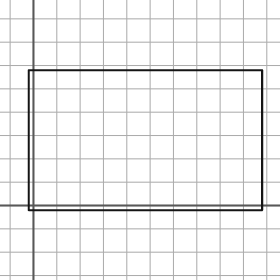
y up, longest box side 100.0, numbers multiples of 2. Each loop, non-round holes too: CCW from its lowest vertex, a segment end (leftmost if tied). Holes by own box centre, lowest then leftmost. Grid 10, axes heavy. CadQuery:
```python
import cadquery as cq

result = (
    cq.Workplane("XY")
    .moveTo(-2.0, -2.0)
    .lineTo(98.0, -2.0)
    .lineTo(98.0, 58.0)
    .lineTo(-2.0, 58.0)
    .close()
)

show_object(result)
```